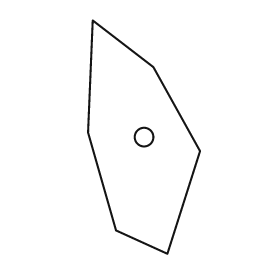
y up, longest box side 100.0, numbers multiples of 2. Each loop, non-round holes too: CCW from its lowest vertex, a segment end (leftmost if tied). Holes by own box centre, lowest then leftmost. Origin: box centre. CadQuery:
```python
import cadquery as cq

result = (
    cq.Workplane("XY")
    .moveTo(10.0, -50.0)
    .lineTo(24.0, -6.0)
    .lineTo(4.0, 30.0)
    .lineTo(-22.0, 50.0)
    .lineTo(-24.0, 2.0)
    .lineTo(-12.0, -40.0)
    .close()
    .moveTo(0.0, 0.0)
    .circle(4.0)
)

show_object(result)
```